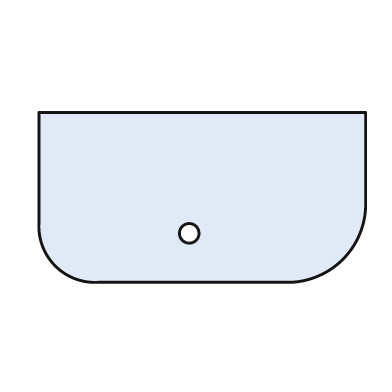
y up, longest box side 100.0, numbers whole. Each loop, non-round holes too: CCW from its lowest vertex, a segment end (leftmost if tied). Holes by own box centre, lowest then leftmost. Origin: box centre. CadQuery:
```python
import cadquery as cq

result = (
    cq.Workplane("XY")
    .moveTo(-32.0, -26.0)
    .lineTo(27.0, -26.0)
    .threePointArc((43.0, -19.0), (50.0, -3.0))
    .lineTo(50.0, 26.0)
    .lineTo(-50.0, 26.0)
    .lineTo(-50.0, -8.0)
    .threePointArc((-45.0, -21.0), (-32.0, -26.0))
    .close()
    .moveTo(-4.0, -11.0)
    .circle(3.0)
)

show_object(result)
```